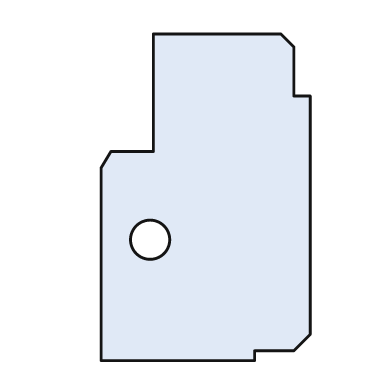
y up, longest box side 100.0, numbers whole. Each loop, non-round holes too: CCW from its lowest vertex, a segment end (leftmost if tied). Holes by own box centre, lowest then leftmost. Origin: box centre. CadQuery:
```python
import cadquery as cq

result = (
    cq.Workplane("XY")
    .moveTo(-32.0, -50.0)
    .lineTo(15.0, -50.0)
    .lineTo(15.0, -47.0)
    .lineTo(27.0, -47.0)
    .lineTo(32.0, -42.0)
    .lineTo(32.0, 31.0)
    .lineTo(27.0, 31.0)
    .lineTo(27.0, 46.0)
    .lineTo(23.0, 50.0)
    .lineTo(-16.0, 50.0)
    .lineTo(-16.0, 14.0)
    .lineTo(-29.0, 14.0)
    .lineTo(-32.0, 9.0)
    .close()
    .moveTo(-17.0, -13.0)
    .circle(6.0)
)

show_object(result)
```